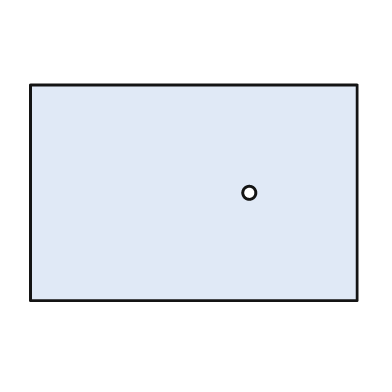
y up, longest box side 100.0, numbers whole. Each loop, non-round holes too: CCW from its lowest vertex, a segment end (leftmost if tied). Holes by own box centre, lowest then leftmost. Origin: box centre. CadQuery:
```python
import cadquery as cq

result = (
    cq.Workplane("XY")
    .moveTo(-50.0, -33.0)
    .lineTo(50.0, -33.0)
    .lineTo(50.0, 33.0)
    .lineTo(-50.0, 33.0)
    .close()
    .moveTo(17.0, 0.0)
    .circle(2.0)
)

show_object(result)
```